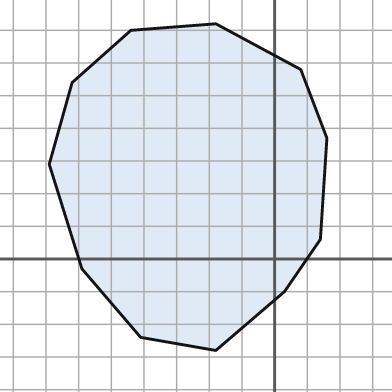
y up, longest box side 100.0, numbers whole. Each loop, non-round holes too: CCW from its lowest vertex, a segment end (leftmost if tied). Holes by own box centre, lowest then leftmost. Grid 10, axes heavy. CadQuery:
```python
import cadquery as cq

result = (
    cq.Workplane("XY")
    .moveTo(-18.0, -28.0)
    .lineTo(3.0, -10.0)
    .lineTo(14.0, 6.0)
    .lineTo(16.0, 37.0)
    .lineTo(8.0, 58.0)
    .lineTo(-18.0, 72.0)
    .lineTo(-44.0, 70.0)
    .lineTo(-62.0, 54.0)
    .lineTo(-69.0, 29.0)
    .lineTo(-59.0, -3.0)
    .lineTo(-41.0, -24.0)
    .close()
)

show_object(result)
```